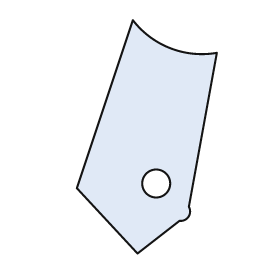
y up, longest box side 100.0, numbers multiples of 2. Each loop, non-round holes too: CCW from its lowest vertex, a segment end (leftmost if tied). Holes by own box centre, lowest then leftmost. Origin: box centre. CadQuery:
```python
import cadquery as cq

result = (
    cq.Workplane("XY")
    .moveTo(-4.0, -50.0)
    .lineTo(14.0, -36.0)
    .threePointArc((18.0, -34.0), (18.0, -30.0))
    .lineTo(30.0, 36.0)
    .threePointArc((10.0, 38.0), (-6.0, 50.0))
    .lineTo(-30.0, -22.0)
    .close()
    .moveTo(4.0, -20.0)
    .circle(6.0)
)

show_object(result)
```